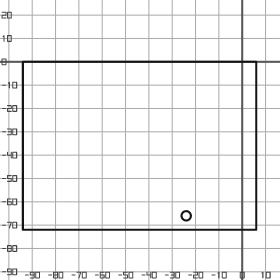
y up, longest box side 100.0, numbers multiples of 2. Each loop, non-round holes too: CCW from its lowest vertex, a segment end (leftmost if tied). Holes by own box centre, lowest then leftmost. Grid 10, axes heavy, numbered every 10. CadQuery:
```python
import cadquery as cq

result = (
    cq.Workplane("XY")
    .moveTo(-94.0, -72.0)
    .lineTo(6.0, -72.0)
    .lineTo(6.0, 0.0)
    .lineTo(-94.0, 0.0)
    .close()
    .moveTo(-24.0, -66.0)
    .circle(2.0)
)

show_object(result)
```